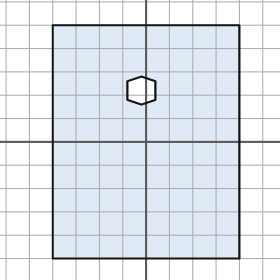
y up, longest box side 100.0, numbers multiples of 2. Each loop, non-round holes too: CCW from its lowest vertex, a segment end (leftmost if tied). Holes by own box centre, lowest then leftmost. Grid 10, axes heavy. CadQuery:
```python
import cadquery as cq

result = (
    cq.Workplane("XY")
    .moveTo(-40.0, -50.0)
    .lineTo(40.0, -50.0)
    .lineTo(40.0, 50.0)
    .lineTo(-40.0, 50.0)
    .close()
    .moveTo(-2.0, 16.0)
    .lineTo(4.0, 18.0)
    .lineTo(4.0, 26.0)
    .lineTo(-2.0, 28.0)
    .lineTo(-8.0, 26.0)
    .lineTo(-8.0, 18.0)
    .close()
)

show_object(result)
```